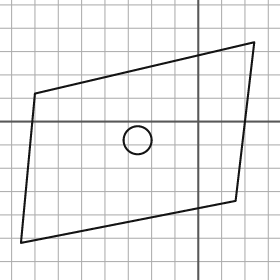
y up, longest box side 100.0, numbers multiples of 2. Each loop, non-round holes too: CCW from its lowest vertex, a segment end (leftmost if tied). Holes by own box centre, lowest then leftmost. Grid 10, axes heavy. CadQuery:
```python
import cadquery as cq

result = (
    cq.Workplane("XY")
    .moveTo(-76.0, -52.0)
    .lineTo(16.0, -34.0)
    .lineTo(24.0, 34.0)
    .lineTo(-70.0, 12.0)
    .close()
    .moveTo(-26.0, -8.0)
    .circle(6.0)
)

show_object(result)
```